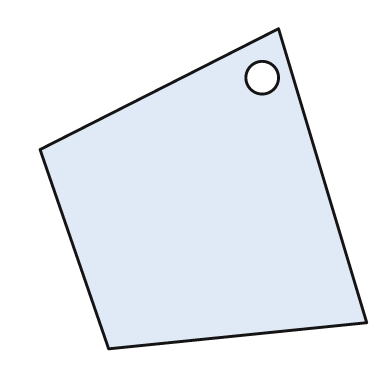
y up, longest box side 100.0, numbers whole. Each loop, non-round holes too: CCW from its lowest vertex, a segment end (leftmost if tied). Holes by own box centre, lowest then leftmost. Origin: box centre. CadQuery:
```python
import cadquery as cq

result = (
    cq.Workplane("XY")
    .moveTo(-29.0, -49.0)
    .lineTo(50.0, -41.0)
    .lineTo(23.0, 49.0)
    .lineTo(-50.0, 12.0)
    .close()
    .moveTo(18.0, 34.0)
    .circle(5.0)
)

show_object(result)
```